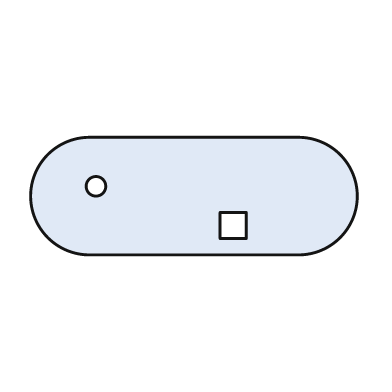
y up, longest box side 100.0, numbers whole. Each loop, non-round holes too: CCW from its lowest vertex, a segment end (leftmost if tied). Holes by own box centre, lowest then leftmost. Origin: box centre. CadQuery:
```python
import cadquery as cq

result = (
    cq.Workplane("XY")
    .moveTo(-32.0, -18.0)
    .lineTo(32.0, -18.0)
    .threePointArc((50.0, 0.0), (32.0, 18.0))
    .lineTo(-32.0, 18.0)
    .threePointArc((-50.0, 0.0), (-32.0, -18.0))
    .close()
    .moveTo(8.0, -13.0)
    .lineTo(16.0, -13.0)
    .lineTo(16.0, -5.0)
    .lineTo(8.0, -5.0)
    .close()
    .moveTo(-30.0, 3.0)
    .circle(3.0)
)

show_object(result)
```